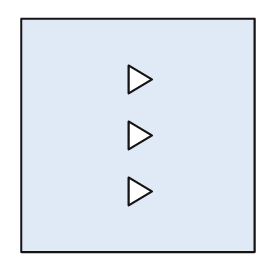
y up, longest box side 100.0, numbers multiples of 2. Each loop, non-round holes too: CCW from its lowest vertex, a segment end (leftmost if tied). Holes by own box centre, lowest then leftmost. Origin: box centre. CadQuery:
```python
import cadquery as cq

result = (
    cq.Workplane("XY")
    .moveTo(-50.0, -50.0)
    .lineTo(50.0, -50.0)
    .lineTo(50.0, 50.0)
    .lineTo(-50.0, 50.0)
    .close()
    .moveTo(-4.0, -30.0)
    .lineTo(6.0, -24.0)
    .lineTo(-4.0, -18.0)
    .close()
    .moveTo(-4.0, -6.0)
    .lineTo(6.0, 0.0)
    .lineTo(-4.0, 6.0)
    .close()
    .moveTo(-4.0, 18.0)
    .lineTo(6.0, 24.0)
    .lineTo(-4.0, 30.0)
    .close()
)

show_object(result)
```